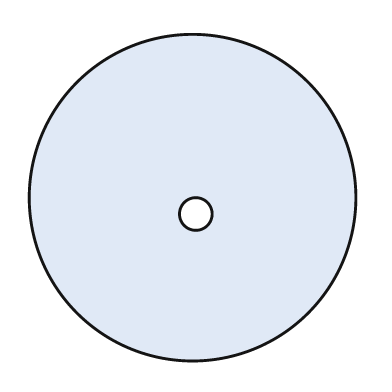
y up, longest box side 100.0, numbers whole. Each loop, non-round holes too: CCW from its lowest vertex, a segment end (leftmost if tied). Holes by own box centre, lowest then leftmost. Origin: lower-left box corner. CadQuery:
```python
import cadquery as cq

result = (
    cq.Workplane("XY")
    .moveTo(50.0, 50.0)
    .circle(50.0)
    .moveTo(51.0, 45.0)
    .circle(5.0)
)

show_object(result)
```